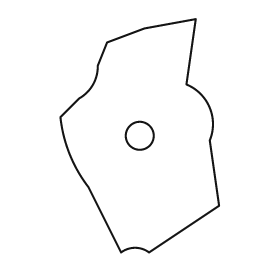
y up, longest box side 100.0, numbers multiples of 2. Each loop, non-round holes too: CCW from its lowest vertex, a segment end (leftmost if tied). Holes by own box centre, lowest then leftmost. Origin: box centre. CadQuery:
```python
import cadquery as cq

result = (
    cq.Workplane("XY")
    .moveTo(-8.0, -50.0)
    .threePointArc((-2.0, -48.0), (4.0, -50.0))
    .lineTo(34.0, -30.0)
    .lineTo(30.0, -2.0)
    .threePointArc((30.0, 12.0), (20.0, 22.0))
    .lineTo(24.0, 50.0)
    .lineTo(2.0, 46.0)
    .lineTo(-14.0, 40.0)
    .lineTo(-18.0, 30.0)
    .threePointArc((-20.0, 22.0), (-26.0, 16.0))
    .lineTo(-34.0, 8.0)
    .threePointArc((-30.0, -8.0), (-22.0, -22.0))
    .close()
    .moveTo(0.0, 0.0)
    .circle(6.0)
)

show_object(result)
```